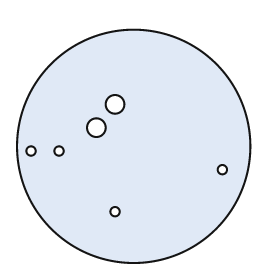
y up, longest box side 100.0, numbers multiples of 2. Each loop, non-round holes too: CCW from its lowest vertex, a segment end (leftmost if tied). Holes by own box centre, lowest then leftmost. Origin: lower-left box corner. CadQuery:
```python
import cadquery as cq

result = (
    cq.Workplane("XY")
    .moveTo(50.0, 50.0)
    .circle(50.0)
    .moveTo(42.0, 22.0)
    .circle(2.0)
    .moveTo(88.0, 40.0)
    .circle(2.0)
    .moveTo(6.0, 48.0)
    .circle(2.0)
    .moveTo(18.0, 48.0)
    .circle(2.0)
    .moveTo(34.0, 58.0)
    .circle(4.0)
    .moveTo(42.0, 68.0)
    .circle(4.0)
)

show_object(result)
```